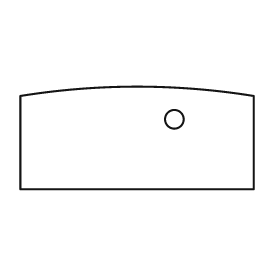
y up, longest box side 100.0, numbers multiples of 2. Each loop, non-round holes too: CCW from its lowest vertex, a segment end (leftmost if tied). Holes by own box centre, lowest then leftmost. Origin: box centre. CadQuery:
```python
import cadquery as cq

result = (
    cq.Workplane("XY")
    .moveTo(-50.0, -22.0)
    .lineTo(50.0, -22.0)
    .lineTo(50.0, 18.0)
    .threePointArc((0.0, 22.0), (-50.0, 18.0))
    .close()
    .moveTo(16.0, 8.0)
    .circle(4.0)
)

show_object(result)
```